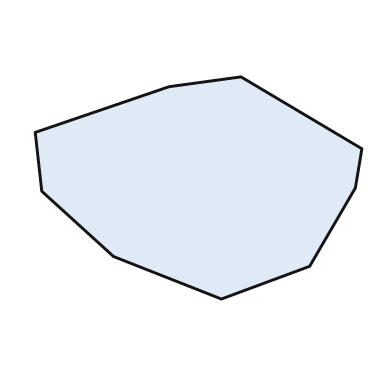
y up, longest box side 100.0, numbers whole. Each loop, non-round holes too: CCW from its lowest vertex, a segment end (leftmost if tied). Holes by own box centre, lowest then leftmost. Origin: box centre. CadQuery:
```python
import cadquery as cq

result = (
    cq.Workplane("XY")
    .moveTo(7.0, -34.0)
    .lineTo(34.0, -24.0)
    .lineTo(48.0, 0.0)
    .lineTo(50.0, 12.0)
    .lineTo(13.0, 34.0)
    .lineTo(-9.0, 31.0)
    .lineTo(-50.0, 17.0)
    .lineTo(-48.0, -1.0)
    .lineTo(-26.0, -21.0)
    .close()
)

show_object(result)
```